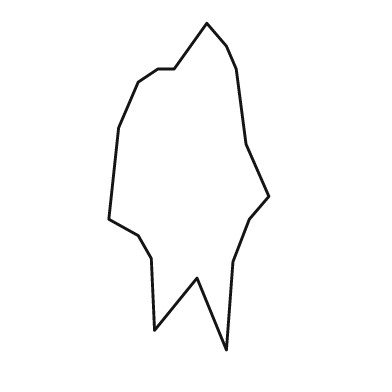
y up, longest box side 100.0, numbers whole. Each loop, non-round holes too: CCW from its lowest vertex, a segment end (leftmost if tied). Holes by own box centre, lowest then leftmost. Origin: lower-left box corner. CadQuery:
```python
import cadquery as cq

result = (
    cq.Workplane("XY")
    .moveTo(36.0, 0.0)
    .lineTo(38.0, 27.0)
    .lineTo(43.0, 40.0)
    .lineTo(49.0, 47.0)
    .lineTo(42.0, 63.0)
    .lineTo(39.0, 86.0)
    .lineTo(36.0, 93.0)
    .lineTo(30.0, 100.0)
    .lineTo(20.0, 86.0)
    .lineTo(15.0, 86.0)
    .lineTo(9.0, 82.0)
    .lineTo(3.0, 68.0)
    .lineTo(0.0, 40.0)
    .lineTo(9.0, 35.0)
    .lineTo(13.0, 28.0)
    .lineTo(14.0, 6.0)
    .lineTo(27.0, 22.0)
    .close()
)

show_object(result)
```